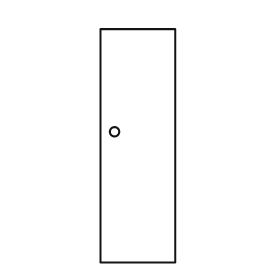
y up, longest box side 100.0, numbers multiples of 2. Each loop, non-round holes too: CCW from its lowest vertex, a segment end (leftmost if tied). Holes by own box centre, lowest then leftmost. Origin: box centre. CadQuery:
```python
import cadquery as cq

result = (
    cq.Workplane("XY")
    .moveTo(-16.0, -50.0)
    .lineTo(16.0, -50.0)
    .lineTo(16.0, 50.0)
    .lineTo(-16.0, 50.0)
    .close()
    .moveTo(-10.0, 6.0)
    .circle(2.0)
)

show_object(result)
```